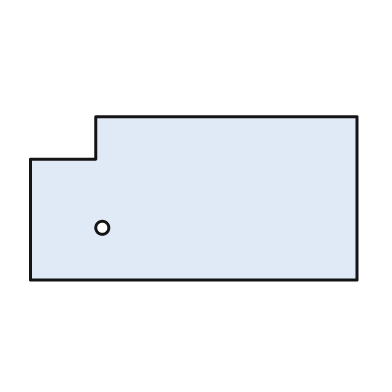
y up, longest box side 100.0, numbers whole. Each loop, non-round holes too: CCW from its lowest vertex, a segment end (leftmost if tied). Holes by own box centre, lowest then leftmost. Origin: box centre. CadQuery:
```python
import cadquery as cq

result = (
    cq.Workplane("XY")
    .moveTo(-50.0, -25.0)
    .lineTo(50.0, -25.0)
    .lineTo(50.0, 25.0)
    .lineTo(-30.0, 25.0)
    .lineTo(-30.0, 12.0)
    .lineTo(-50.0, 12.0)
    .close()
    .moveTo(-28.0, -9.0)
    .circle(2.0)
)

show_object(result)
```